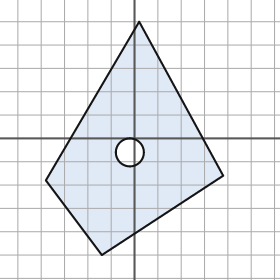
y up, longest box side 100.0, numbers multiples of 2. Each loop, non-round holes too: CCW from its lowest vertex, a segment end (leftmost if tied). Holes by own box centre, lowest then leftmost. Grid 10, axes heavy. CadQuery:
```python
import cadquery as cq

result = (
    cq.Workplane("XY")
    .moveTo(-14.0, -50.0)
    .lineTo(38.0, -16.0)
    .lineTo(2.0, 50.0)
    .lineTo(-38.0, -18.0)
    .close()
    .moveTo(-2.0, -6.0)
    .circle(6.0)
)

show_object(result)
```